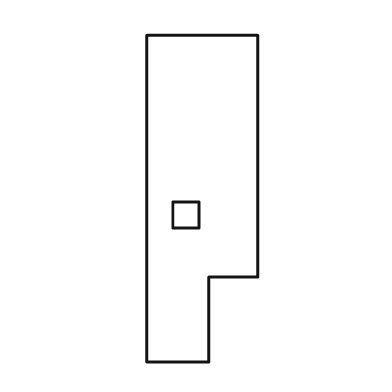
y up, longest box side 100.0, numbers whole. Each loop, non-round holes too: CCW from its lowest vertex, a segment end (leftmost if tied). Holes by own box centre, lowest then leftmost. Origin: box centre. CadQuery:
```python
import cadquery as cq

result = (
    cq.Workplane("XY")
    .moveTo(-17.0, -50.0)
    .lineTo(2.0, -50.0)
    .lineTo(2.0, -24.0)
    .lineTo(17.0, -24.0)
    .lineTo(17.0, 50.0)
    .lineTo(-17.0, 50.0)
    .close()
    .moveTo(-9.0, -9.0)
    .lineTo(-1.0, -9.0)
    .lineTo(-1.0, -1.0)
    .lineTo(-9.0, -1.0)
    .close()
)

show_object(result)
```